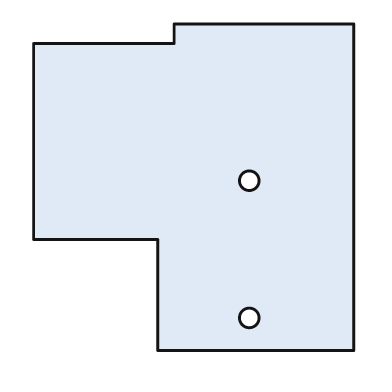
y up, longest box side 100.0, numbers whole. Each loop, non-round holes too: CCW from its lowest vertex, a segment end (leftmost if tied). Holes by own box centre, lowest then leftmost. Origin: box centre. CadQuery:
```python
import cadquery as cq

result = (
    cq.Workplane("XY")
    .moveTo(-11.0, -50.0)
    .lineTo(49.0, -50.0)
    .lineTo(49.0, 50.0)
    .lineTo(-6.0, 50.0)
    .lineTo(-6.0, 44.0)
    .lineTo(-49.0, 44.0)
    .lineTo(-49.0, -16.0)
    .lineTo(-11.0, -16.0)
    .close()
    .moveTo(17.0, -40.0)
    .circle(3.0)
    .moveTo(17.0, 2.0)
    .circle(3.0)
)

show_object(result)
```